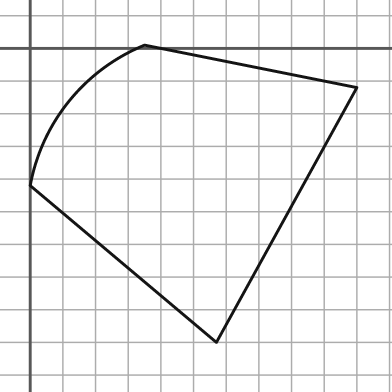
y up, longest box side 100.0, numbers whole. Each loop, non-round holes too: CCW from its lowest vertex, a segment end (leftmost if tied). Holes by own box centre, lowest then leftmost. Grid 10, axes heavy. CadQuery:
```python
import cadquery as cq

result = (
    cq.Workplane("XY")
    .moveTo(57.0, -90.0)
    .lineTo(100.0, -12.0)
    .lineTo(35.0, 1.0)
    .threePointArc((12.0, -16.0), (0.0, -42.0))
    .close()
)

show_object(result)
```